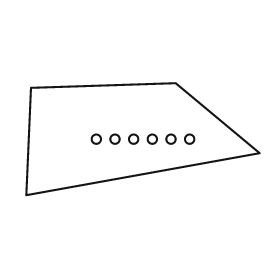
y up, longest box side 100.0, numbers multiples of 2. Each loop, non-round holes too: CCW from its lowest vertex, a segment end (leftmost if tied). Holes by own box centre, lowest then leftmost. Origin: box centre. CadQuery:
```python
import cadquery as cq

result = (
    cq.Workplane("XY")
    .moveTo(-50.0, -24.0)
    .lineTo(50.0, -6.0)
    .lineTo(14.0, 24.0)
    .lineTo(-48.0, 22.0)
    .close()
    .moveTo(-20.0, 0.0)
    .circle(2.0)
    .moveTo(-12.0, 0.0)
    .circle(2.0)
    .moveTo(-4.0, 0.0)
    .circle(2.0)
    .moveTo(4.0, 0.0)
    .circle(2.0)
    .moveTo(12.0, 0.0)
    .circle(2.0)
    .moveTo(20.0, 0.0)
    .circle(2.0)
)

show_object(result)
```